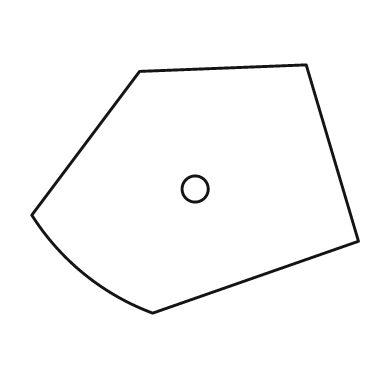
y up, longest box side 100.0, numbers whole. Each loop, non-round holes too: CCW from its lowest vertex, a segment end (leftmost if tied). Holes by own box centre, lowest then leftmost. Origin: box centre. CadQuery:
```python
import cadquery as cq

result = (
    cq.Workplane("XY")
    .moveTo(-13.0, -38.0)
    .lineTo(50.0, -16.0)
    .lineTo(34.0, 38.0)
    .lineTo(-17.0, 36.0)
    .lineTo(-50.0, -8.0)
    .threePointArc((-34.0, -26.0), (-13.0, -38.0))
    .close()
    .moveTo(0.0, 0.0)
    .circle(4.0)
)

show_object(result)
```